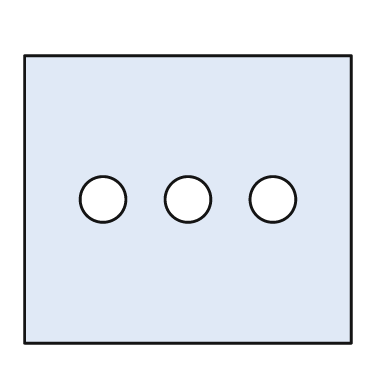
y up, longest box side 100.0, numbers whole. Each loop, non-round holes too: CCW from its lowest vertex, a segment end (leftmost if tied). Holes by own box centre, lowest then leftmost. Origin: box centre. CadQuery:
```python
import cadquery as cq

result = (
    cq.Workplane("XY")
    .moveTo(-50.0, -44.0)
    .lineTo(50.0, -44.0)
    .lineTo(50.0, 44.0)
    .lineTo(-50.0, 44.0)
    .close()
    .moveTo(-26.0, 0.0)
    .circle(7.0)
    .moveTo(0.0, 0.0)
    .circle(7.0)
    .moveTo(26.0, 0.0)
    .circle(7.0)
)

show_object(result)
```